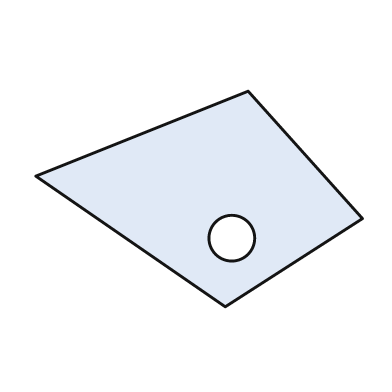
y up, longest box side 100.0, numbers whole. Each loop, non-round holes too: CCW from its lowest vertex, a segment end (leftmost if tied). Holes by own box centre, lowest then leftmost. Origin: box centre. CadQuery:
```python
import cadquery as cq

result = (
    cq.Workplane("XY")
    .moveTo(8.0, -33.0)
    .lineTo(50.0, -6.0)
    .lineTo(15.0, 33.0)
    .lineTo(-50.0, 7.0)
    .close()
    .moveTo(10.0, -12.0)
    .circle(7.0)
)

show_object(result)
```